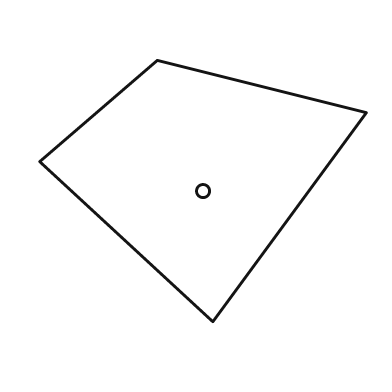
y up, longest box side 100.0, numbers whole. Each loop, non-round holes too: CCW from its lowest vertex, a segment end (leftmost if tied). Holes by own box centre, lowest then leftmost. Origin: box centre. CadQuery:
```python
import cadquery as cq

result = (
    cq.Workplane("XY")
    .moveTo(3.0, -40.0)
    .lineTo(50.0, 24.0)
    .lineTo(-14.0, 40.0)
    .lineTo(-50.0, 9.0)
    .close()
    .moveTo(0.0, 0.0)
    .circle(2.0)
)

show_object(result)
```